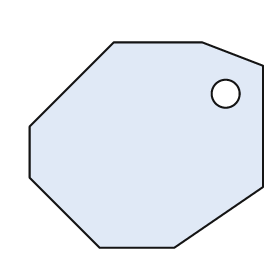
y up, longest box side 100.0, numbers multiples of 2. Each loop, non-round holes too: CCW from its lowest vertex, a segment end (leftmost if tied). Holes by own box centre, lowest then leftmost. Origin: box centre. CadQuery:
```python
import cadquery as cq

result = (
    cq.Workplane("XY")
    .moveTo(-20.0, -44.0)
    .lineTo(12.0, -44.0)
    .lineTo(50.0, -18.0)
    .lineTo(50.0, 34.0)
    .lineTo(24.0, 44.0)
    .lineTo(-14.0, 44.0)
    .lineTo(-50.0, 8.0)
    .lineTo(-50.0, -14.0)
    .close()
    .moveTo(34.0, 22.0)
    .circle(6.0)
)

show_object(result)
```